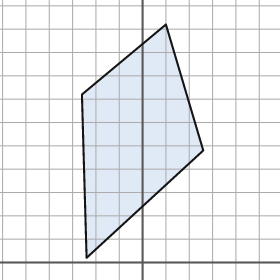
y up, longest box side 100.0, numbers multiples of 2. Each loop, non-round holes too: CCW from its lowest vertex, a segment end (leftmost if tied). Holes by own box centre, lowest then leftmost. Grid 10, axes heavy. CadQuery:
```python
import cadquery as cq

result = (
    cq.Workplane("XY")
    .moveTo(-24.0, 2.0)
    .lineTo(26.0, 48.0)
    .lineTo(10.0, 102.0)
    .lineTo(-26.0, 72.0)
    .close()
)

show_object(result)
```